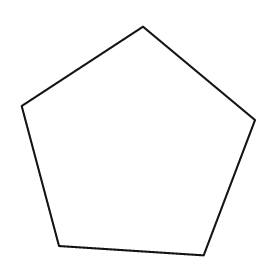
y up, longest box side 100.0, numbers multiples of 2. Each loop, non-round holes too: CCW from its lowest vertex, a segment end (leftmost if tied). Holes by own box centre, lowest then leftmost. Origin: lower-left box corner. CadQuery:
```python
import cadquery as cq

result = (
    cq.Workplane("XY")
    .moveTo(78.0, 0.0)
    .lineTo(100.0, 58.0)
    .lineTo(52.0, 98.0)
    .lineTo(0.0, 64.0)
    .lineTo(16.0, 4.0)
    .close()
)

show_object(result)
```